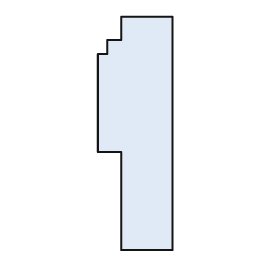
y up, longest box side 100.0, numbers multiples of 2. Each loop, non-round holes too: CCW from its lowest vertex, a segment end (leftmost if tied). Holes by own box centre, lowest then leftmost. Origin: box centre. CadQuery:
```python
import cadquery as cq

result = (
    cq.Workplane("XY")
    .moveTo(-6.0, -50.0)
    .lineTo(16.0, -50.0)
    .lineTo(16.0, 50.0)
    .lineTo(-6.0, 50.0)
    .lineTo(-6.0, 40.0)
    .lineTo(-12.0, 40.0)
    .lineTo(-12.0, 34.0)
    .lineTo(-16.0, 34.0)
    .lineTo(-16.0, -8.0)
    .lineTo(-6.0, -8.0)
    .close()
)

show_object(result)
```